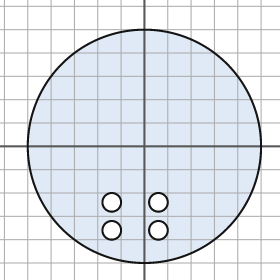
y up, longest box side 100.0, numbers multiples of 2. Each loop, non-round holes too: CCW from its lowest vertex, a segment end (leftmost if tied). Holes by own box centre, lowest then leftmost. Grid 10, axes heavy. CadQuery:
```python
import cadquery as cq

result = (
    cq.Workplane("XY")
    .moveTo(0.0, 0.0)
    .circle(50.0)
    .moveTo(-14.0, -36.0)
    .circle(4.0)
    .moveTo(6.0, -36.0)
    .circle(4.0)
    .moveTo(-14.0, -24.0)
    .circle(4.0)
    .moveTo(6.0, -24.0)
    .circle(4.0)
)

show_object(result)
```